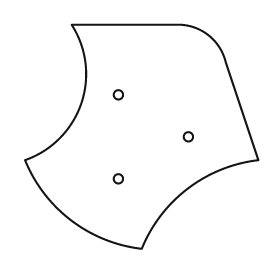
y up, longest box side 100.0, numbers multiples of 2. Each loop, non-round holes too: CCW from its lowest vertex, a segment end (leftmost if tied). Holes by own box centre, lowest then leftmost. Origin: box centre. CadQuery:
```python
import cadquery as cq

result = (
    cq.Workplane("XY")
    .moveTo(0.0, -48.0)
    .threePointArc((20.0, -22.0), (50.0, -10.0))
    .lineTo(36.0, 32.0)
    .threePointArc((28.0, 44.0), (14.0, 48.0))
    .lineTo(-30.0, 48.0)
    .threePointArc((-26.0, 14.0), (-50.0, -10.0))
    .threePointArc((-30.0, -36.0), (0.0, -48.0))
    .close()
    .moveTo(-10.0, -18.0)
    .circle(2.0)
    .moveTo(20.0, 0.0)
    .circle(2.0)
    .moveTo(-10.0, 18.0)
    .circle(2.0)
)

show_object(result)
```